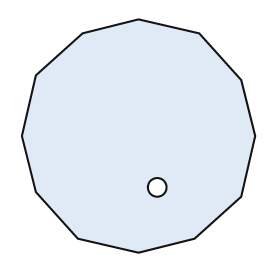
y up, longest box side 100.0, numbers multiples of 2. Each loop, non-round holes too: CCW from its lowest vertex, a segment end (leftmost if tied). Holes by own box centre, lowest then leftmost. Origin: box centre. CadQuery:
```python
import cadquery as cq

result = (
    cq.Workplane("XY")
    .moveTo(0.0, -50.0)
    .lineTo(24.0, -44.0)
    .lineTo(44.0, -26.0)
    .lineTo(50.0, 0.0)
    .lineTo(44.0, 24.0)
    .lineTo(26.0, 44.0)
    .lineTo(0.0, 50.0)
    .lineTo(-24.0, 44.0)
    .lineTo(-44.0, 26.0)
    .lineTo(-50.0, 0.0)
    .lineTo(-44.0, -24.0)
    .lineTo(-26.0, -44.0)
    .close()
    .moveTo(8.0, -22.0)
    .circle(4.0)
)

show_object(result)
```